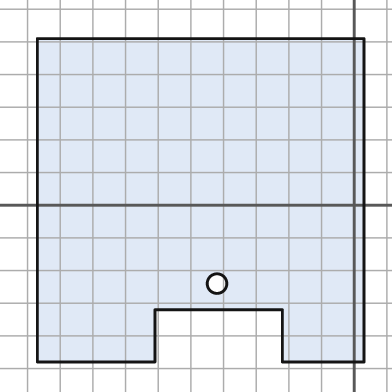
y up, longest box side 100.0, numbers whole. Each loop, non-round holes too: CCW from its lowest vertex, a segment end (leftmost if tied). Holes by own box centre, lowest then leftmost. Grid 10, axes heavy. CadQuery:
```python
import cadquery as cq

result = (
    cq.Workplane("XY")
    .moveTo(-97.0, -48.0)
    .lineTo(-61.0, -48.0)
    .lineTo(-61.0, -32.0)
    .lineTo(-22.0, -32.0)
    .lineTo(-22.0, -48.0)
    .lineTo(3.0, -48.0)
    .lineTo(3.0, 51.0)
    .lineTo(-97.0, 51.0)
    .close()
    .moveTo(-42.0, -24.0)
    .circle(3.0)
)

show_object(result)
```